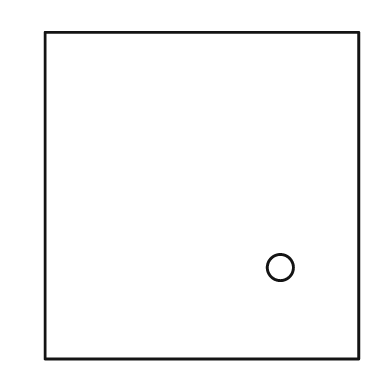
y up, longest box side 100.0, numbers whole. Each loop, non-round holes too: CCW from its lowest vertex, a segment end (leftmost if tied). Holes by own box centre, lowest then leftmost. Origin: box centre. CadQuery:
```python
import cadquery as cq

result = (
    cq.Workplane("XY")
    .moveTo(-48.0, -50.0)
    .lineTo(48.0, -50.0)
    .lineTo(48.0, 50.0)
    .lineTo(-48.0, 50.0)
    .close()
    .moveTo(24.0, -22.0)
    .circle(4.0)
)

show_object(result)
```